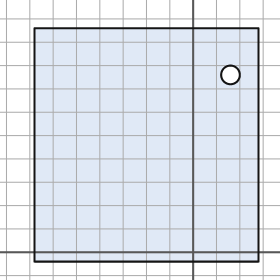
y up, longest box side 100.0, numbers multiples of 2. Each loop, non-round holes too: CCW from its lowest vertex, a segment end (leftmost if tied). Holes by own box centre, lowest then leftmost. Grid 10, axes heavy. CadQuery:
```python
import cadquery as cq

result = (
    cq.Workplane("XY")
    .moveTo(-68.0, -4.0)
    .lineTo(28.0, -4.0)
    .lineTo(28.0, 96.0)
    .lineTo(-68.0, 96.0)
    .close()
    .moveTo(16.0, 76.0)
    .circle(4.0)
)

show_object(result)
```